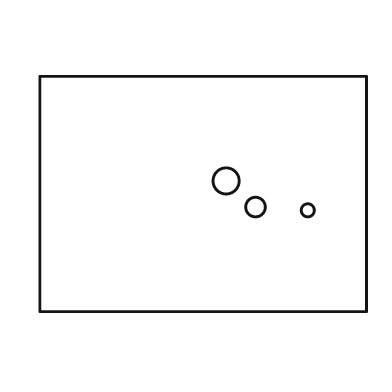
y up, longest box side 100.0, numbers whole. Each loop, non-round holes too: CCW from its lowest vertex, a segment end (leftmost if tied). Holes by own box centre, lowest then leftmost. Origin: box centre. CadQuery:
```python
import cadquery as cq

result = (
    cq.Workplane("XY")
    .moveTo(-50.0, -36.0)
    .lineTo(50.0, -36.0)
    .lineTo(50.0, 36.0)
    .lineTo(-50.0, 36.0)
    .close()
    .moveTo(32.0, -5.0)
    .circle(2.0)
    .moveTo(16.0, -4.0)
    .circle(3.0)
    .moveTo(7.0, 4.0)
    .circle(4.0)
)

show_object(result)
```